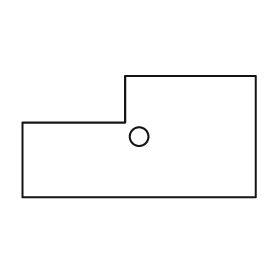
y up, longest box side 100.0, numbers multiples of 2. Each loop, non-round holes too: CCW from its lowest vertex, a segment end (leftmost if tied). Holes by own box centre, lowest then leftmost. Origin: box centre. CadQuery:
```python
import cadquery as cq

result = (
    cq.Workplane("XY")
    .moveTo(-50.0, -26.0)
    .lineTo(50.0, -26.0)
    .lineTo(50.0, 26.0)
    .lineTo(-6.0, 26.0)
    .lineTo(-6.0, 6.0)
    .lineTo(-50.0, 6.0)
    .close()
    .moveTo(0.0, 0.0)
    .circle(4.0)
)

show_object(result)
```